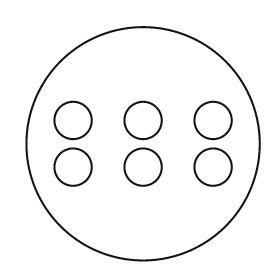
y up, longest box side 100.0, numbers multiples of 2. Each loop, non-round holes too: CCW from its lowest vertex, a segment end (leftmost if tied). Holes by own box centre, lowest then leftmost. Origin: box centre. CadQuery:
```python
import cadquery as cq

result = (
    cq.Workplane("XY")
    .moveTo(0.0, 0.0)
    .circle(50.0)
    .moveTo(-30.0, -10.0)
    .circle(8.0)
    .moveTo(0.0, -10.0)
    .circle(8.0)
    .moveTo(30.0, -10.0)
    .circle(8.0)
    .moveTo(-30.0, 10.0)
    .circle(8.0)
    .moveTo(0.0, 10.0)
    .circle(8.0)
    .moveTo(30.0, 10.0)
    .circle(8.0)
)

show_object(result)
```